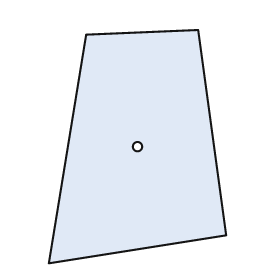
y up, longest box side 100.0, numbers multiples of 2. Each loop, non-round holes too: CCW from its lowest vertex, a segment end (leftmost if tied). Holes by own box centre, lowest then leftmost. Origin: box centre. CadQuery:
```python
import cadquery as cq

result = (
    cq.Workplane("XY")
    .moveTo(-38.0, -50.0)
    .lineTo(38.0, -38.0)
    .lineTo(26.0, 50.0)
    .lineTo(-22.0, 48.0)
    .close()
    .moveTo(0.0, 0.0)
    .circle(2.0)
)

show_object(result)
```